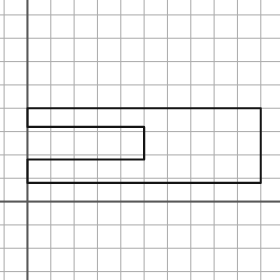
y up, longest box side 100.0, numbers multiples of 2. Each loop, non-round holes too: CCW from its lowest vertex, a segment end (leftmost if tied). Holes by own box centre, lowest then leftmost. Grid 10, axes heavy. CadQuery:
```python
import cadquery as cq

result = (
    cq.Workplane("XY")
    .moveTo(0.0, 8.0)
    .lineTo(100.0, 8.0)
    .lineTo(100.0, 40.0)
    .lineTo(0.0, 40.0)
    .lineTo(0.0, 32.0)
    .lineTo(50.0, 32.0)
    .lineTo(50.0, 18.0)
    .lineTo(0.0, 18.0)
    .close()
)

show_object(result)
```